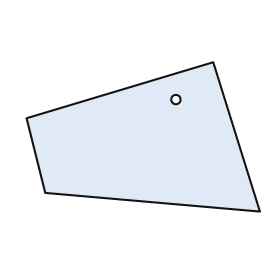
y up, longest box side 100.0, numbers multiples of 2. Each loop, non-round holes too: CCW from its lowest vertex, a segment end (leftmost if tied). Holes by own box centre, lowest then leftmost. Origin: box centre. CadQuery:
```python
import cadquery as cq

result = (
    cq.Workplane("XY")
    .moveTo(50.0, -32.0)
    .lineTo(30.0, 32.0)
    .lineTo(-50.0, 8.0)
    .lineTo(-42.0, -24.0)
    .close()
    .moveTo(14.0, 16.0)
    .circle(2.0)
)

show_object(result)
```